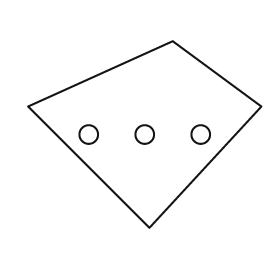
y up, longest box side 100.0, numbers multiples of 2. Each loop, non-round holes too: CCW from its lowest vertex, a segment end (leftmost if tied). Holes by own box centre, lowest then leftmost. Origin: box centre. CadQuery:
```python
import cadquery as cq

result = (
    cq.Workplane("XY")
    .moveTo(2.0, -40.0)
    .lineTo(50.0, 12.0)
    .lineTo(12.0, 40.0)
    .lineTo(-50.0, 12.0)
    .close()
    .moveTo(-24.0, 0.0)
    .circle(4.0)
    .moveTo(0.0, 0.0)
    .circle(4.0)
    .moveTo(24.0, 0.0)
    .circle(4.0)
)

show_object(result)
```